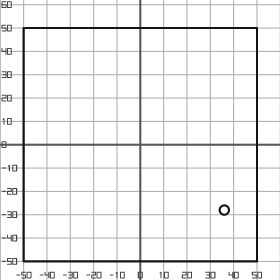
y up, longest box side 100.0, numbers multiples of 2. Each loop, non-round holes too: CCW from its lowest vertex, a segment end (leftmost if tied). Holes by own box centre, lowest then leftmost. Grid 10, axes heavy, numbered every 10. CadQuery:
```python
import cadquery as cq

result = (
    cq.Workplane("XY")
    .moveTo(-50.0, -50.0)
    .lineTo(50.0, -50.0)
    .lineTo(50.0, 50.0)
    .lineTo(-50.0, 50.0)
    .close()
    .moveTo(36.0, -28.0)
    .circle(2.0)
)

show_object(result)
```